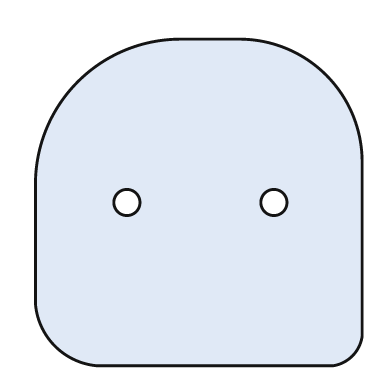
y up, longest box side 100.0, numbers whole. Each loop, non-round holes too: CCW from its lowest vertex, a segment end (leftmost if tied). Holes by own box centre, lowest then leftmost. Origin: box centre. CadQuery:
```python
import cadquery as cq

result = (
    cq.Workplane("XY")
    .moveTo(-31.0, -50.0)
    .lineTo(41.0, -50.0)
    .threePointArc((47.0, -47.0), (50.0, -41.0))
    .lineTo(50.0, 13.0)
    .threePointArc((39.0, 39.0), (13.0, 50.0))
    .lineTo(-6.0, 50.0)
    .threePointArc((-37.0, 37.0), (-50.0, 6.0))
    .lineTo(-50.0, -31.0)
    .threePointArc((-44.0, -44.0), (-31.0, -50.0))
    .close()
    .moveTo(-22.0, 0.0)
    .circle(4.0)
    .moveTo(23.0, 0.0)
    .circle(4.0)
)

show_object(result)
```